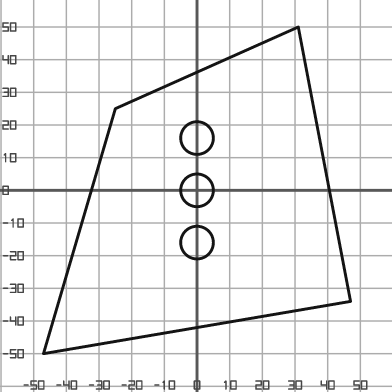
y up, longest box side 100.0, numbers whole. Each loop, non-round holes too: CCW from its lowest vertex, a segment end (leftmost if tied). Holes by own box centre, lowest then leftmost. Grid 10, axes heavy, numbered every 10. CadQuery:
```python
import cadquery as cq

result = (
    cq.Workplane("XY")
    .moveTo(-47.0, -50.0)
    .lineTo(47.0, -34.0)
    .lineTo(31.0, 50.0)
    .lineTo(-25.0, 25.0)
    .close()
    .moveTo(0.0, -16.0)
    .circle(5.0)
    .moveTo(0.0, 0.0)
    .circle(5.0)
    .moveTo(0.0, 16.0)
    .circle(5.0)
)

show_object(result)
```